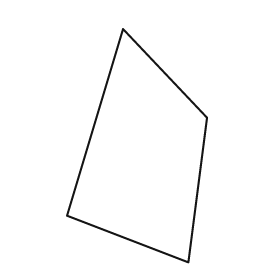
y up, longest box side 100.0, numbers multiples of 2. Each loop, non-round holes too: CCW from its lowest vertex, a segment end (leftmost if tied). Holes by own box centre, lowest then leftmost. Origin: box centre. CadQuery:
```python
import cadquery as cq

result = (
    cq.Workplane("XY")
    .moveTo(22.0, -50.0)
    .lineTo(30.0, 12.0)
    .lineTo(-6.0, 50.0)
    .lineTo(-30.0, -30.0)
    .close()
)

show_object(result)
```